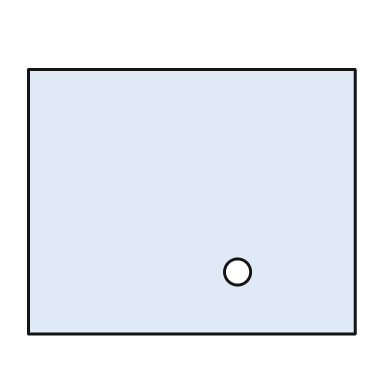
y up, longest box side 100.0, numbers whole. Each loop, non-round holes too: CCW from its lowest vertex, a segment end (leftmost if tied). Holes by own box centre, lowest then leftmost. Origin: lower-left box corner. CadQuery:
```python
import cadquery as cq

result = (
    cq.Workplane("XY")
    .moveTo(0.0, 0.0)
    .lineTo(100.0, 0.0)
    .lineTo(100.0, 81.0)
    .lineTo(0.0, 81.0)
    .close()
    .moveTo(64.0, 19.0)
    .circle(4.0)
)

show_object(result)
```